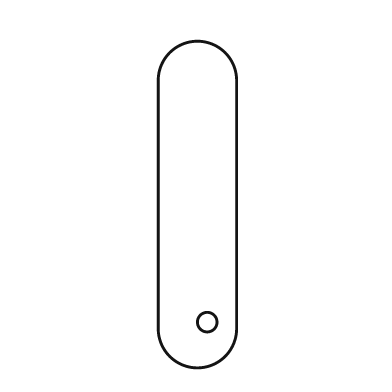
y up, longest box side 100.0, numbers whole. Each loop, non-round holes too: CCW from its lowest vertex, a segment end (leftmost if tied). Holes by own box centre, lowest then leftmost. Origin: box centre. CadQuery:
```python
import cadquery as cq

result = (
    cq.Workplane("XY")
    .moveTo(-12.0, -38.0)
    .threePointArc((0.0, -50.0), (12.0, -38.0))
    .lineTo(12.0, 38.0)
    .threePointArc((0.0, 50.0), (-12.0, 38.0))
    .close()
    .moveTo(3.0, -36.0)
    .circle(3.0)
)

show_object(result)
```